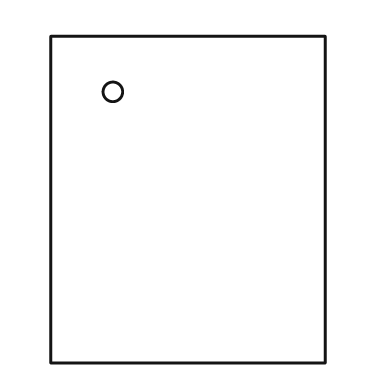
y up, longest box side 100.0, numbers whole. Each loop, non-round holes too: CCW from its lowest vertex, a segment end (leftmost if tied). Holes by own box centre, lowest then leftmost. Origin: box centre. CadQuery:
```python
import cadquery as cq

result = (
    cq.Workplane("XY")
    .moveTo(-42.0, -50.0)
    .lineTo(42.0, -50.0)
    .lineTo(42.0, 50.0)
    .lineTo(-42.0, 50.0)
    .close()
    .moveTo(-23.0, 33.0)
    .circle(3.0)
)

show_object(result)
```